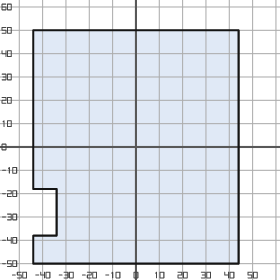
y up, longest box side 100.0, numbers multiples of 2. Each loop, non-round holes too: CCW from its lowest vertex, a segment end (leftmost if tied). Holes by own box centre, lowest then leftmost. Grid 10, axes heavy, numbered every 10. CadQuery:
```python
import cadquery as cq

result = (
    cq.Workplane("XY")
    .moveTo(-44.0, -50.0)
    .lineTo(44.0, -50.0)
    .lineTo(44.0, 50.0)
    .lineTo(-44.0, 50.0)
    .lineTo(-44.0, -18.0)
    .lineTo(-34.0, -18.0)
    .lineTo(-34.0, -38.0)
    .lineTo(-44.0, -38.0)
    .close()
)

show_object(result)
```